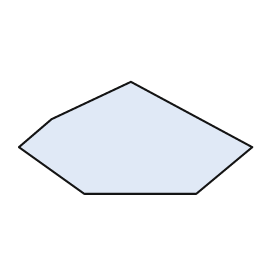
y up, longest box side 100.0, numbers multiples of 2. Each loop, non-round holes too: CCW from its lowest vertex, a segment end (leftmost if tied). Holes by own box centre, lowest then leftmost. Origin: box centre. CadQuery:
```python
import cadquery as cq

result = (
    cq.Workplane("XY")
    .moveTo(-22.0, -24.0)
    .lineTo(26.0, -24.0)
    .lineTo(50.0, -4.0)
    .lineTo(-2.0, 24.0)
    .lineTo(-36.0, 8.0)
    .lineTo(-50.0, -4.0)
    .close()
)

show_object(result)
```